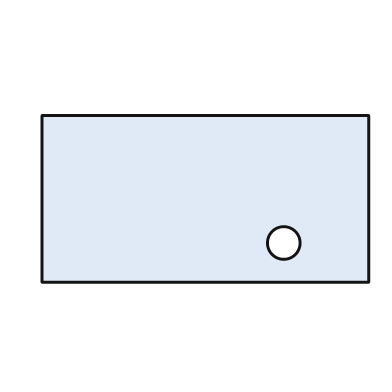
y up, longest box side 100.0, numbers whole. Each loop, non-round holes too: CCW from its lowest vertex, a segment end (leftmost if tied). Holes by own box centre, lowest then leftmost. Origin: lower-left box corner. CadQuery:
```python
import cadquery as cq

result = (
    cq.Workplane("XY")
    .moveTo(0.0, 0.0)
    .lineTo(100.0, 0.0)
    .lineTo(100.0, 51.0)
    .lineTo(0.0, 51.0)
    .close()
    .moveTo(74.0, 12.0)
    .circle(5.0)
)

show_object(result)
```